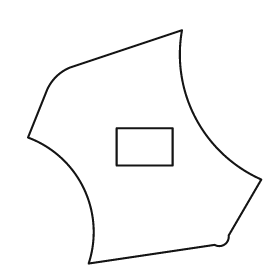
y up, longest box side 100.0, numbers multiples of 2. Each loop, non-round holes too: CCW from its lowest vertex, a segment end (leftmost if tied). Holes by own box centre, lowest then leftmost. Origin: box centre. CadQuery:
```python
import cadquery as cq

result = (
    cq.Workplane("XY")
    .moveTo(-24.0, -50.0)
    .lineTo(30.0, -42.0)
    .threePointArc((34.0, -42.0), (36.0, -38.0))
    .lineTo(50.0, -14.0)
    .threePointArc((22.0, 12.0), (16.0, 50.0))
    .lineTo(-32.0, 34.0)
    .threePointArc((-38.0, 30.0), (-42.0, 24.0))
    .lineTo(-50.0, 4.0)
    .threePointArc((-26.0, -18.0), (-24.0, -50.0))
    .close()
    .moveTo(-12.0, -8.0)
    .lineTo(12.0, -8.0)
    .lineTo(12.0, 8.0)
    .lineTo(-12.0, 8.0)
    .close()
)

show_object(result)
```